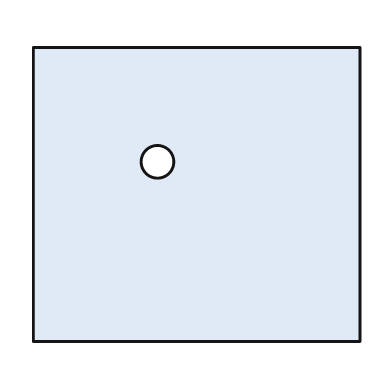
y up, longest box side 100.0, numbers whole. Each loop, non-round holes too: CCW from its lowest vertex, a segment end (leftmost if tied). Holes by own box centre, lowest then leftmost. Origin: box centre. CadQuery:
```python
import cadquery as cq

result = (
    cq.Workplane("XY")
    .moveTo(-50.0, -45.0)
    .lineTo(50.0, -45.0)
    .lineTo(50.0, 45.0)
    .lineTo(-50.0, 45.0)
    .close()
    .moveTo(-12.0, 10.0)
    .circle(5.0)
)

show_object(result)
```